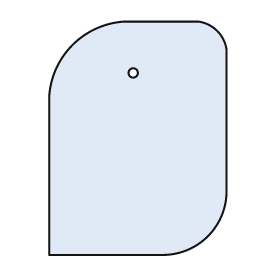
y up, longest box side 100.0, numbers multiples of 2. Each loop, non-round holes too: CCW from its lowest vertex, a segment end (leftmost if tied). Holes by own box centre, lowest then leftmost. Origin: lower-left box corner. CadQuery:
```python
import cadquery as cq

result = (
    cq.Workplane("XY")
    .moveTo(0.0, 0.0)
    .lineTo(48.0, 0.0)
    .threePointArc((68.0, 8.0), (76.0, 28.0))
    .lineTo(76.0, 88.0)
    .threePointArc((72.0, 96.0), (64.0, 100.0))
    .lineTo(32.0, 100.0)
    .threePointArc((10.0, 90.0), (0.0, 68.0))
    .close()
    .moveTo(36.0, 78.0)
    .circle(2.0)
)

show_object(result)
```